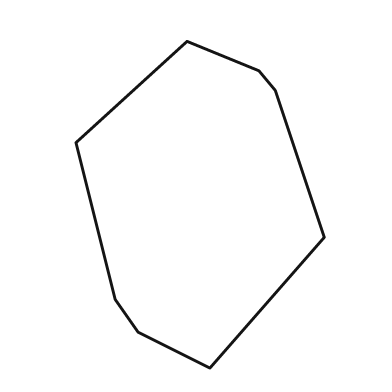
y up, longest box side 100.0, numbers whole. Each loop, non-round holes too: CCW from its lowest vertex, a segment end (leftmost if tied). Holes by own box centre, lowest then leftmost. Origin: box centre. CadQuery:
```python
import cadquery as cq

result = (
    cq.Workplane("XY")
    .moveTo(3.0, -50.0)
    .lineTo(38.0, -10.0)
    .lineTo(23.0, 35.0)
    .lineTo(18.0, 41.0)
    .lineTo(-4.0, 50.0)
    .lineTo(-38.0, 19.0)
    .lineTo(-26.0, -29.0)
    .lineTo(-19.0, -39.0)
    .close()
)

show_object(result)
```